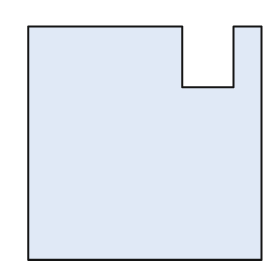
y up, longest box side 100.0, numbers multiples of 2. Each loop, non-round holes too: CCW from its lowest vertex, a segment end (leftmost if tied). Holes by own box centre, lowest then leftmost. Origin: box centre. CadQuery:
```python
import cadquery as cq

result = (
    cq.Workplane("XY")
    .moveTo(-50.0, -50.0)
    .lineTo(50.0, -50.0)
    .lineTo(50.0, 50.0)
    .lineTo(38.0, 50.0)
    .lineTo(38.0, 24.0)
    .lineTo(16.0, 24.0)
    .lineTo(16.0, 50.0)
    .lineTo(-50.0, 50.0)
    .close()
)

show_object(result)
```